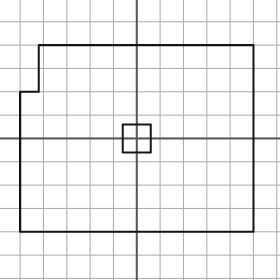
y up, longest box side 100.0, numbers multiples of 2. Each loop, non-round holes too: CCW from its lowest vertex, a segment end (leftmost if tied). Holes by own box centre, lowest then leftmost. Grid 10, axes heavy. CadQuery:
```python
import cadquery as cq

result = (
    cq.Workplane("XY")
    .moveTo(-50.0, -40.0)
    .lineTo(50.0, -40.0)
    .lineTo(50.0, 40.0)
    .lineTo(-42.0, 40.0)
    .lineTo(-42.0, 20.0)
    .lineTo(-50.0, 20.0)
    .close()
    .moveTo(-6.0, -6.0)
    .lineTo(6.0, -6.0)
    .lineTo(6.0, 6.0)
    .lineTo(-6.0, 6.0)
    .close()
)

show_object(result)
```